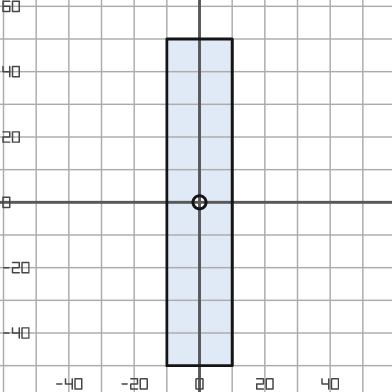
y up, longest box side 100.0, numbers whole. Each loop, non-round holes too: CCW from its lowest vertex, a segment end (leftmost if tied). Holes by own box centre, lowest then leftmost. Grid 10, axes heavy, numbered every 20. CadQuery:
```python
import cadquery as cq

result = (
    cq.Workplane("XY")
    .moveTo(-10.0, -50.0)
    .lineTo(10.0, -50.0)
    .lineTo(10.0, 50.0)
    .lineTo(-10.0, 50.0)
    .close()
    .moveTo(0.0, 0.0)
    .circle(2.0)
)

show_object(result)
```